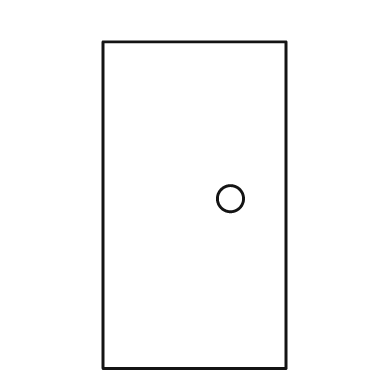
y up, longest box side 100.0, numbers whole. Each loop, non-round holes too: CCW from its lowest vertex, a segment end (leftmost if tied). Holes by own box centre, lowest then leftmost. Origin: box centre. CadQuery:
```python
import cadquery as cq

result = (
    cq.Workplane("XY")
    .moveTo(-28.0, -50.0)
    .lineTo(28.0, -50.0)
    .lineTo(28.0, 50.0)
    .lineTo(-28.0, 50.0)
    .close()
    .moveTo(11.0, 2.0)
    .circle(4.0)
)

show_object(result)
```